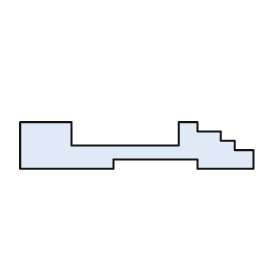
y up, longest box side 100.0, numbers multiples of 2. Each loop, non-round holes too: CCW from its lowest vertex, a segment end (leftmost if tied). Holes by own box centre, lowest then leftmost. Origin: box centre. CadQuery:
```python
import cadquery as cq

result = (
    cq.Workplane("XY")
    .moveTo(-50.0, -10.0)
    .lineTo(-10.0, -10.0)
    .lineTo(-10.0, -6.0)
    .lineTo(26.0, -6.0)
    .lineTo(26.0, -10.0)
    .lineTo(50.0, -10.0)
    .lineTo(50.0, -2.0)
    .lineTo(42.0, -2.0)
    .lineTo(42.0, 2.0)
    .lineTo(36.0, 2.0)
    .lineTo(36.0, 6.0)
    .lineTo(26.0, 6.0)
    .lineTo(26.0, 10.0)
    .lineTo(18.0, 10.0)
    .lineTo(18.0, 0.0)
    .lineTo(-28.0, 0.0)
    .lineTo(-28.0, 10.0)
    .lineTo(-50.0, 10.0)
    .close()
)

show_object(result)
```